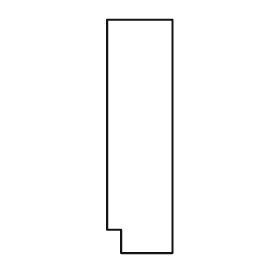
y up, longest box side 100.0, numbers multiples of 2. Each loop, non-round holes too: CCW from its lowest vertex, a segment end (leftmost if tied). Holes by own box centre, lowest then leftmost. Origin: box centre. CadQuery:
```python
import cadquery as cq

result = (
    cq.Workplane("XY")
    .moveTo(-8.0, -50.0)
    .lineTo(14.0, -50.0)
    .lineTo(14.0, 50.0)
    .lineTo(-14.0, 50.0)
    .lineTo(-14.0, -40.0)
    .lineTo(-8.0, -40.0)
    .close()
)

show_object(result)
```